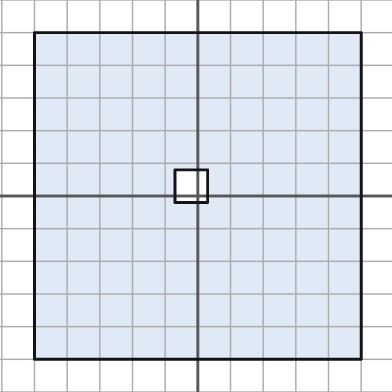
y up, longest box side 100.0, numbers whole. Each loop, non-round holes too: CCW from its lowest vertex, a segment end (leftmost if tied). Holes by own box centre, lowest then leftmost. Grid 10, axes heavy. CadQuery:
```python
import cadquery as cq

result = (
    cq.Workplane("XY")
    .moveTo(-50.0, -50.0)
    .lineTo(50.0, -50.0)
    .lineTo(50.0, 50.0)
    .lineTo(-50.0, 50.0)
    .close()
    .moveTo(-7.0, -2.0)
    .lineTo(3.0, -2.0)
    .lineTo(3.0, 8.0)
    .lineTo(-7.0, 8.0)
    .close()
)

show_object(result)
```